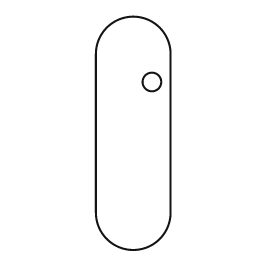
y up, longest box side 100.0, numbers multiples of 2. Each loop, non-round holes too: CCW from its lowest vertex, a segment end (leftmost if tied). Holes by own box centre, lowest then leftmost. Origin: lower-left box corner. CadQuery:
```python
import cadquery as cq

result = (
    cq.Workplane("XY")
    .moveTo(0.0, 16.0)
    .threePointArc((16.0, 0.0), (32.0, 16.0))
    .lineTo(32.0, 84.0)
    .threePointArc((16.0, 100.0), (0.0, 84.0))
    .close()
    .moveTo(24.0, 72.0)
    .circle(4.0)
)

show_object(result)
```